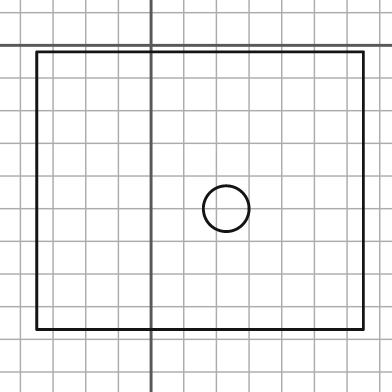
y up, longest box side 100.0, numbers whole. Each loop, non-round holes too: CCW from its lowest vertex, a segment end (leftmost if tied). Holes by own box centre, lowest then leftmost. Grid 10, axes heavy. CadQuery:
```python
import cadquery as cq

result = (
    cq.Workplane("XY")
    .moveTo(-35.0, -87.0)
    .lineTo(65.0, -87.0)
    .lineTo(65.0, -2.0)
    .lineTo(-35.0, -2.0)
    .close()
    .moveTo(23.0, -50.0)
    .circle(7.0)
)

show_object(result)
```